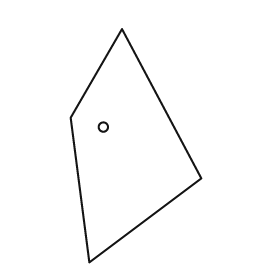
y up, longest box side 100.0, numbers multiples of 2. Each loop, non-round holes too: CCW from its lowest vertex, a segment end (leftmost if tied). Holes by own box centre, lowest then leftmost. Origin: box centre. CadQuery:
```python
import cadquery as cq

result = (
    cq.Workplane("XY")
    .moveTo(-20.0, -50.0)
    .lineTo(28.0, -14.0)
    .lineTo(-6.0, 50.0)
    .lineTo(-28.0, 12.0)
    .close()
    .moveTo(-14.0, 8.0)
    .circle(2.0)
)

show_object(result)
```